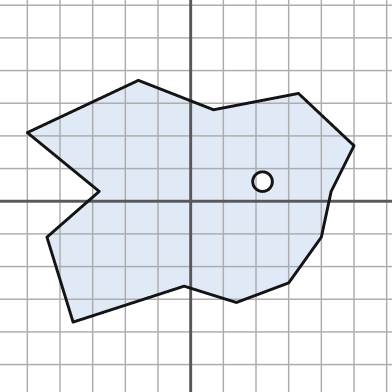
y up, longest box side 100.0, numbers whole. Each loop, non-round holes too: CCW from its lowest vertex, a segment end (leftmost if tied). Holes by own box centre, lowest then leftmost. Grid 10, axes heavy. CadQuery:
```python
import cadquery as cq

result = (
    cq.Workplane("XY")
    .moveTo(-36.0, -37.0)
    .lineTo(-2.0, -26.0)
    .lineTo(14.0, -31.0)
    .lineTo(30.0, -25.0)
    .lineTo(40.0, -11.0)
    .lineTo(43.0, 3.0)
    .lineTo(50.0, 17.0)
    .lineTo(33.0, 33.0)
    .lineTo(7.0, 28.0)
    .lineTo(-16.0, 37.0)
    .lineTo(-50.0, 21.0)
    .lineTo(-28.0, 3.0)
    .lineTo(-44.0, -11.0)
    .close()
    .moveTo(22.0, 6.0)
    .circle(3.0)
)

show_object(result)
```